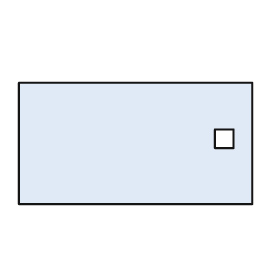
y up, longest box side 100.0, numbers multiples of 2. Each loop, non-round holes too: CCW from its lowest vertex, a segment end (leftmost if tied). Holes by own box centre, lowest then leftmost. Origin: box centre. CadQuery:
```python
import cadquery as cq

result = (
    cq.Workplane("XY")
    .moveTo(-50.0, -26.0)
    .lineTo(50.0, -26.0)
    .lineTo(50.0, 26.0)
    .lineTo(-50.0, 26.0)
    .close()
    .moveTo(34.0, -2.0)
    .lineTo(42.0, -2.0)
    .lineTo(42.0, 6.0)
    .lineTo(34.0, 6.0)
    .close()
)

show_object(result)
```